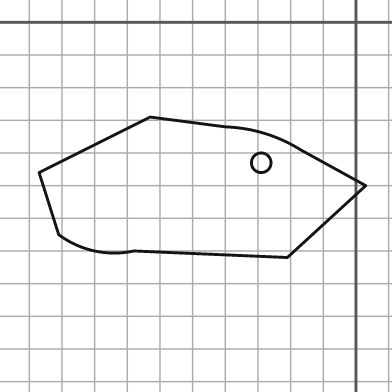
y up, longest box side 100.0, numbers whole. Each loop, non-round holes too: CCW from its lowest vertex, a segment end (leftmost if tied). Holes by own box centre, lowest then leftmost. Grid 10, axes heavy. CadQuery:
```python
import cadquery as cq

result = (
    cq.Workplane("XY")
    .moveTo(-21.0, -72.0)
    .lineTo(3.0, -50.0)
    .lineTo(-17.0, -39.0)
    .threePointArc((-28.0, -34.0), (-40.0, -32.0))
    .lineTo(-63.0, -29.0)
    .lineTo(-97.0, -46.0)
    .lineTo(-91.0, -65.0)
    .threePointArc((-80.0, -70.0), (-68.0, -70.0))
    .close()
    .moveTo(-29.0, -43.0)
    .circle(3.0)
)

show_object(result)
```